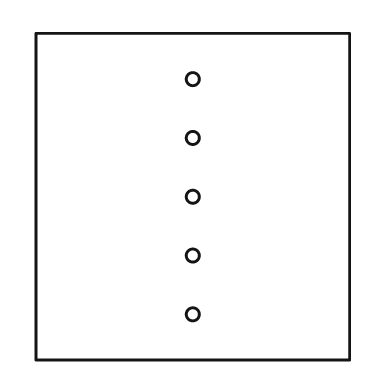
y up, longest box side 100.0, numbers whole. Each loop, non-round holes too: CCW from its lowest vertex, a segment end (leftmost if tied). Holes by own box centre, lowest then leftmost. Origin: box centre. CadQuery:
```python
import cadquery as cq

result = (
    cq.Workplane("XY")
    .moveTo(-48.0, -50.0)
    .lineTo(48.0, -50.0)
    .lineTo(48.0, 50.0)
    .lineTo(-48.0, 50.0)
    .close()
    .moveTo(0.0, -36.0)
    .circle(2.0)
    .moveTo(0.0, -18.0)
    .circle(2.0)
    .moveTo(0.0, 0.0)
    .circle(2.0)
    .moveTo(0.0, 18.0)
    .circle(2.0)
    .moveTo(0.0, 36.0)
    .circle(2.0)
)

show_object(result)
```